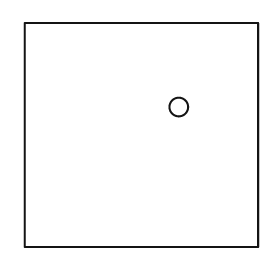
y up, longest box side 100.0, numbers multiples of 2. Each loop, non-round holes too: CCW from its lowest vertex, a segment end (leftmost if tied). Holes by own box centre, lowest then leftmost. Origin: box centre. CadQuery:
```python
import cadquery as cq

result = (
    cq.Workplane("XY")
    .moveTo(-50.0, -48.0)
    .lineTo(50.0, -48.0)
    .lineTo(50.0, 48.0)
    .lineTo(-50.0, 48.0)
    .close()
    .moveTo(16.0, 12.0)
    .circle(4.0)
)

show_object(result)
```